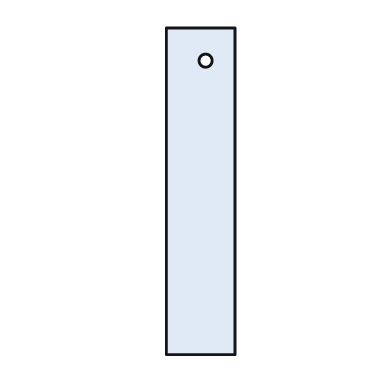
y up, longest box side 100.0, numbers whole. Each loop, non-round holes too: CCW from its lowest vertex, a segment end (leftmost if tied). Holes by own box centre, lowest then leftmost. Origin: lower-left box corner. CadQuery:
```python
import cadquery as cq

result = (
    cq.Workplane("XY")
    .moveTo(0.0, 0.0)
    .lineTo(21.0, 0.0)
    .lineTo(21.0, 100.0)
    .lineTo(0.0, 100.0)
    .close()
    .moveTo(12.0, 90.0)
    .circle(2.0)
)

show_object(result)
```